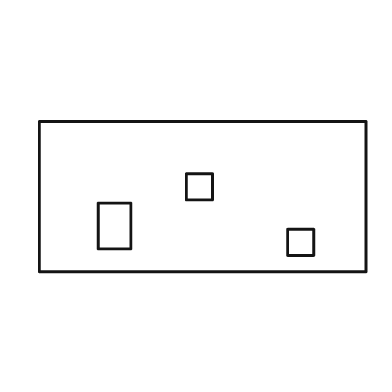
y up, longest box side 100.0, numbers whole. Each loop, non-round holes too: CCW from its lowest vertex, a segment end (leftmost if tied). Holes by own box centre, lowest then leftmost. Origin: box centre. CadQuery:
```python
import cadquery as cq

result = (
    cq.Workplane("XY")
    .moveTo(-50.0, -23.0)
    .lineTo(50.0, -23.0)
    .lineTo(50.0, 23.0)
    .lineTo(-50.0, 23.0)
    .close()
    .moveTo(26.0, -18.0)
    .lineTo(34.0, -18.0)
    .lineTo(34.0, -10.0)
    .lineTo(26.0, -10.0)
    .close()
    .moveTo(-32.0, -16.0)
    .lineTo(-22.0, -16.0)
    .lineTo(-22.0, -2.0)
    .lineTo(-32.0, -2.0)
    .close()
    .moveTo(-5.0, -1.0)
    .lineTo(3.0, -1.0)
    .lineTo(3.0, 7.0)
    .lineTo(-5.0, 7.0)
    .close()
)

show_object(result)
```